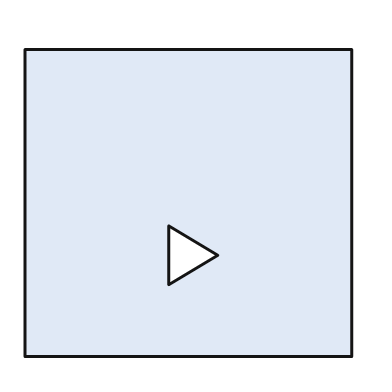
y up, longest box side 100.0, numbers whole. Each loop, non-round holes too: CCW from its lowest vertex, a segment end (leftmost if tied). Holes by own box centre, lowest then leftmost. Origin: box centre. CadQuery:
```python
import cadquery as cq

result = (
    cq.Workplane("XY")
    .moveTo(-50.0, -47.0)
    .lineTo(50.0, -47.0)
    .lineTo(50.0, 47.0)
    .lineTo(-50.0, 47.0)
    .close()
    .moveTo(-6.0, -25.0)
    .lineTo(9.0, -16.0)
    .lineTo(-6.0, -7.0)
    .close()
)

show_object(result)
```